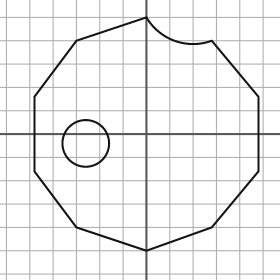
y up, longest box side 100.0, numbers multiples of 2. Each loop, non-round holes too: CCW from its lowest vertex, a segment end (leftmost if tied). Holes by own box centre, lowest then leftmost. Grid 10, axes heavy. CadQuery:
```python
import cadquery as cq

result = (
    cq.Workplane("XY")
    .moveTo(0.0, -50.0)
    .lineTo(28.0, -40.0)
    .lineTo(48.0, -16.0)
    .lineTo(48.0, 16.0)
    .lineTo(28.0, 40.0)
    .threePointArc((12.0, 40.0), (0.0, 50.0))
    .lineTo(-30.0, 40.0)
    .lineTo(-48.0, 16.0)
    .lineTo(-48.0, -16.0)
    .lineTo(-30.0, -40.0)
    .close()
    .moveTo(-26.0, -4.0)
    .circle(10.0)
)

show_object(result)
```